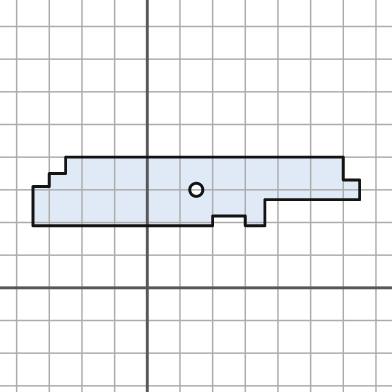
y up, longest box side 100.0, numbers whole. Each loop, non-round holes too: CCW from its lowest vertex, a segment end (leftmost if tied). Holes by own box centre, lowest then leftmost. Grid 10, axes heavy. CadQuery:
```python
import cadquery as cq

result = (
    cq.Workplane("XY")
    .moveTo(-35.0, 19.0)
    .lineTo(20.0, 19.0)
    .lineTo(20.0, 22.0)
    .lineTo(30.0, 22.0)
    .lineTo(30.0, 19.0)
    .lineTo(36.0, 19.0)
    .lineTo(36.0, 27.0)
    .lineTo(65.0, 27.0)
    .lineTo(65.0, 33.0)
    .lineTo(60.0, 33.0)
    .lineTo(60.0, 40.0)
    .lineTo(-25.0, 40.0)
    .lineTo(-25.0, 35.0)
    .lineTo(-30.0, 35.0)
    .lineTo(-30.0, 31.0)
    .lineTo(-35.0, 31.0)
    .close()
    .moveTo(15.0, 30.0)
    .circle(2.0)
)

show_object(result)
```